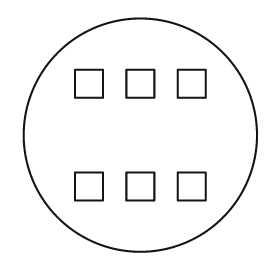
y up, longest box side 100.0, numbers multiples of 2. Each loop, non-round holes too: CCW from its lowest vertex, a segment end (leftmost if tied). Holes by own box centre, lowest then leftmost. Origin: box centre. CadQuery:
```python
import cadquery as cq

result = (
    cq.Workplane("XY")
    .moveTo(0.0, 0.0)
    .circle(50.0)
    .moveTo(-28.0, -28.0)
    .lineTo(-16.0, -28.0)
    .lineTo(-16.0, -16.0)
    .lineTo(-28.0, -16.0)
    .close()
    .moveTo(-6.0, -28.0)
    .lineTo(6.0, -28.0)
    .lineTo(6.0, -16.0)
    .lineTo(-6.0, -16.0)
    .close()
    .moveTo(16.0, -28.0)
    .lineTo(28.0, -28.0)
    .lineTo(28.0, -16.0)
    .lineTo(16.0, -16.0)
    .close()
    .moveTo(-28.0, 16.0)
    .lineTo(-16.0, 16.0)
    .lineTo(-16.0, 28.0)
    .lineTo(-28.0, 28.0)
    .close()
    .moveTo(-6.0, 16.0)
    .lineTo(6.0, 16.0)
    .lineTo(6.0, 28.0)
    .lineTo(-6.0, 28.0)
    .close()
    .moveTo(16.0, 16.0)
    .lineTo(28.0, 16.0)
    .lineTo(28.0, 28.0)
    .lineTo(16.0, 28.0)
    .close()
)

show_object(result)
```